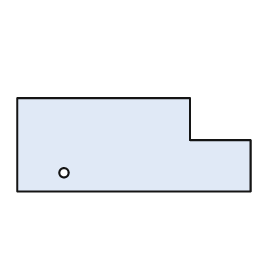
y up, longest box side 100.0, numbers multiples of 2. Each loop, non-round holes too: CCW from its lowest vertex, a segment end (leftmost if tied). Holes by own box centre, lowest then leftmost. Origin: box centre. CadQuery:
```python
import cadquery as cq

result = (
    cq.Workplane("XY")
    .moveTo(-50.0, -20.0)
    .lineTo(50.0, -20.0)
    .lineTo(50.0, 2.0)
    .lineTo(24.0, 2.0)
    .lineTo(24.0, 20.0)
    .lineTo(-50.0, 20.0)
    .close()
    .moveTo(-30.0, -12.0)
    .circle(2.0)
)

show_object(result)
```